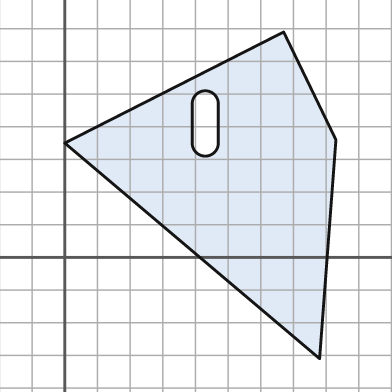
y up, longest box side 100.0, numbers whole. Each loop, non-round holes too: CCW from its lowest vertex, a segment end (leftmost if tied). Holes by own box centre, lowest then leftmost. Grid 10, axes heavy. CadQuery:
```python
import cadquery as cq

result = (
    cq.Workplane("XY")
    .moveTo(78.0, -31.0)
    .lineTo(83.0, 36.0)
    .lineTo(67.0, 69.0)
    .lineTo(0.0, 35.0)
    .close()
    .moveTo(39.0, 35.0)
    .threePointArc((43.0, 31.0), (47.0, 35.0))
    .lineTo(47.0, 47.0)
    .threePointArc((43.0, 51.0), (39.0, 47.0))
    .close()
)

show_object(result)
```